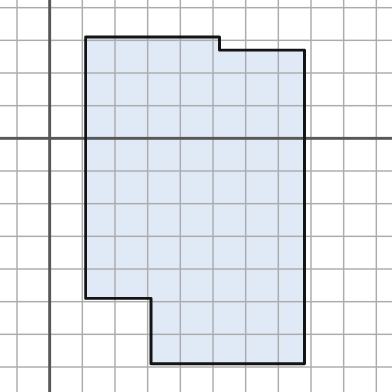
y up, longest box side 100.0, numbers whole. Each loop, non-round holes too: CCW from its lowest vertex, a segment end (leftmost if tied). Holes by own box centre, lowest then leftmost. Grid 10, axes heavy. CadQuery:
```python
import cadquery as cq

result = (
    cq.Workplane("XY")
    .moveTo(31.0, -69.0)
    .lineTo(78.0, -69.0)
    .lineTo(78.0, 27.0)
    .lineTo(52.0, 27.0)
    .lineTo(52.0, 31.0)
    .lineTo(11.0, 31.0)
    .lineTo(11.0, -49.0)
    .lineTo(31.0, -49.0)
    .close()
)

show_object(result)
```